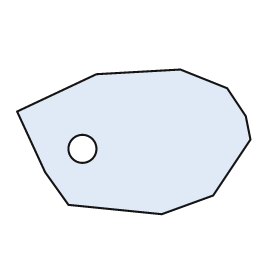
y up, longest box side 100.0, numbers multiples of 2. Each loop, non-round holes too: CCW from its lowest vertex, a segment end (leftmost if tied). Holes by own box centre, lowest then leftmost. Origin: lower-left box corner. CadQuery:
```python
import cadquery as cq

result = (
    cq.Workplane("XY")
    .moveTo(62.0, 0.0)
    .lineTo(84.0, 8.0)
    .lineTo(100.0, 32.0)
    .lineTo(98.0, 42.0)
    .lineTo(90.0, 54.0)
    .lineTo(70.0, 62.0)
    .lineTo(34.0, 60.0)
    .lineTo(0.0, 44.0)
    .lineTo(12.0, 18.0)
    .lineTo(22.0, 4.0)
    .close()
    .moveTo(28.0, 28.0)
    .circle(6.0)
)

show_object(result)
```